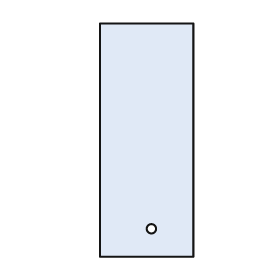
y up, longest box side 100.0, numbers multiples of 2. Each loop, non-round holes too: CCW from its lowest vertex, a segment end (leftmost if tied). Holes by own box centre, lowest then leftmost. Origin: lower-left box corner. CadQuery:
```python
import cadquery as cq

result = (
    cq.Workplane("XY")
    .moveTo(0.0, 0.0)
    .lineTo(40.0, 0.0)
    .lineTo(40.0, 100.0)
    .lineTo(0.0, 100.0)
    .close()
    .moveTo(22.0, 12.0)
    .circle(2.0)
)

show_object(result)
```